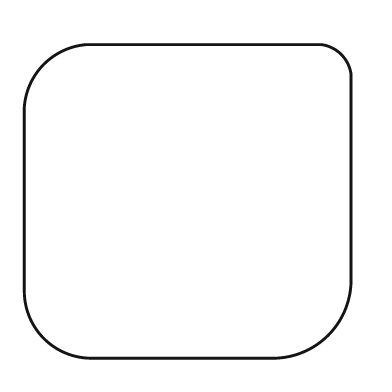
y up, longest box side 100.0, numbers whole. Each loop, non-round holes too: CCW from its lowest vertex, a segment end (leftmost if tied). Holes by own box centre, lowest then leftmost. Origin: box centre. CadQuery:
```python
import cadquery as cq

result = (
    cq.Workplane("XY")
    .moveTo(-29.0, -48.0)
    .lineTo(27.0, -48.0)
    .threePointArc((43.0, -41.0), (50.0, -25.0))
    .lineTo(50.0, 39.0)
    .threePointArc((47.0, 45.0), (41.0, 48.0))
    .lineTo(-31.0, 48.0)
    .threePointArc((-44.0, 42.0), (-50.0, 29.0))
    .lineTo(-50.0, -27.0)
    .threePointArc((-44.0, -42.0), (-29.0, -48.0))
    .close()
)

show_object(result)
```